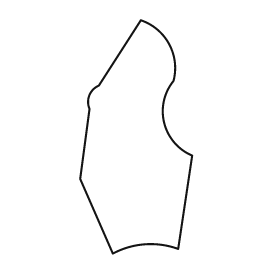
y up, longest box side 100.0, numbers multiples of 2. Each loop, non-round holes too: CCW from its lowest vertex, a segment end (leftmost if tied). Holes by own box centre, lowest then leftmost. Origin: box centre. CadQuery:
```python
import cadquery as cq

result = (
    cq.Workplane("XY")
    .moveTo(-10.0, -50.0)
    .threePointArc((4.0, -46.0), (18.0, -48.0))
    .lineTo(24.0, -8.0)
    .threePointArc((12.0, 6.0), (16.0, 24.0))
    .threePointArc((14.0, 40.0), (2.0, 50.0))
    .lineTo(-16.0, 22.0)
    .threePointArc((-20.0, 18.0), (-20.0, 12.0))
    .lineTo(-24.0, -18.0)
    .close()
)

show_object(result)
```